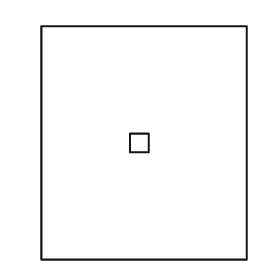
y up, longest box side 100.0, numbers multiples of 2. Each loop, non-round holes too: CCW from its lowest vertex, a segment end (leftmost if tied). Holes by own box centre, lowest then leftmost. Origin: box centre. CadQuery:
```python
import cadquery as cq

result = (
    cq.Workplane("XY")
    .moveTo(-44.0, -50.0)
    .lineTo(44.0, -50.0)
    .lineTo(44.0, 50.0)
    .lineTo(-44.0, 50.0)
    .close()
    .moveTo(-6.0, -4.0)
    .lineTo(2.0, -4.0)
    .lineTo(2.0, 4.0)
    .lineTo(-6.0, 4.0)
    .close()
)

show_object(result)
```